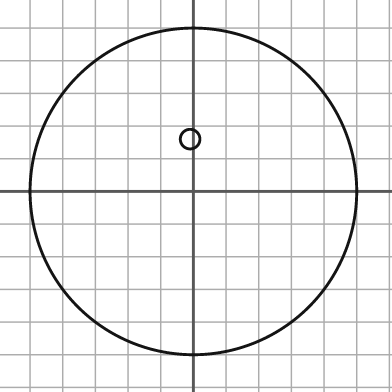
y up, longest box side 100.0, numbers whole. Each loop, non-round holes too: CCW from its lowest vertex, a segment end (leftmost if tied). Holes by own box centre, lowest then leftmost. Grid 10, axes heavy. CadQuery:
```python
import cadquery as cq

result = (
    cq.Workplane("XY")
    .moveTo(0.0, 0.0)
    .circle(50.0)
    .moveTo(-1.0, 16.0)
    .circle(3.0)
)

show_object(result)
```